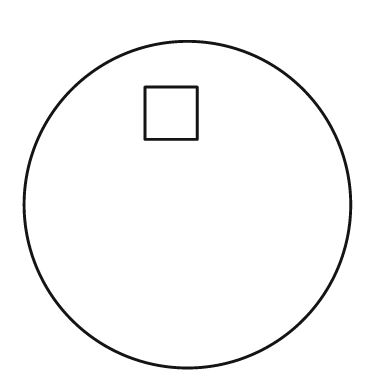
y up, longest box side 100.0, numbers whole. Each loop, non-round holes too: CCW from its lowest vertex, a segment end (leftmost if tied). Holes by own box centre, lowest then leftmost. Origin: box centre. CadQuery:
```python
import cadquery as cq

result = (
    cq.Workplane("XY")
    .moveTo(0.0, 0.0)
    .circle(50.0)
    .moveTo(-13.0, 20.0)
    .lineTo(3.0, 20.0)
    .lineTo(3.0, 36.0)
    .lineTo(-13.0, 36.0)
    .close()
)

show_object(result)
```